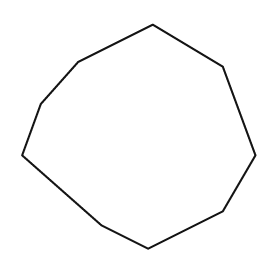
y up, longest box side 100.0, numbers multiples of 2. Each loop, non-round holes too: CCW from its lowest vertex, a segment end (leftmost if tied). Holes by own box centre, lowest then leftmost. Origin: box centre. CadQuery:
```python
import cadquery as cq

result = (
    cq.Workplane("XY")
    .moveTo(4.0, -48.0)
    .lineTo(36.0, -32.0)
    .lineTo(50.0, -8.0)
    .lineTo(36.0, 30.0)
    .lineTo(6.0, 48.0)
    .lineTo(-26.0, 32.0)
    .lineTo(-42.0, 14.0)
    .lineTo(-50.0, -8.0)
    .lineTo(-16.0, -38.0)
    .close()
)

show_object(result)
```